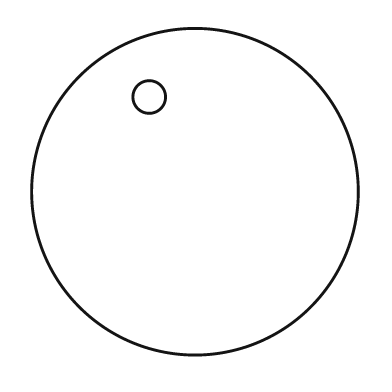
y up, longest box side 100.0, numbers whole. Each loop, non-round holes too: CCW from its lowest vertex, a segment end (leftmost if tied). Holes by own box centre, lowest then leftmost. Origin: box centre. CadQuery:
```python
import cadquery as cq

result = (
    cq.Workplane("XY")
    .moveTo(0.0, 0.0)
    .circle(50.0)
    .moveTo(-14.0, 29.0)
    .circle(5.0)
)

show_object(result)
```